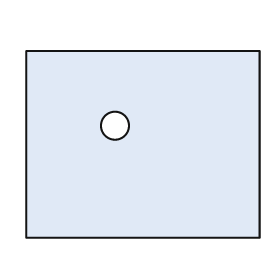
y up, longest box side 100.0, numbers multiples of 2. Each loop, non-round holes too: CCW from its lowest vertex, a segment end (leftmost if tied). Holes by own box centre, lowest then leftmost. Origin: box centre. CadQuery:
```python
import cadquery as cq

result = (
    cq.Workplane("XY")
    .moveTo(-50.0, -40.0)
    .lineTo(50.0, -40.0)
    .lineTo(50.0, 40.0)
    .lineTo(-50.0, 40.0)
    .close()
    .moveTo(-12.0, 8.0)
    .circle(6.0)
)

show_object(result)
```